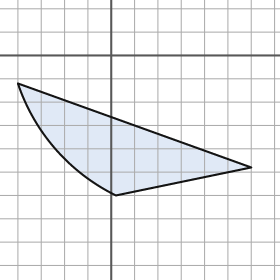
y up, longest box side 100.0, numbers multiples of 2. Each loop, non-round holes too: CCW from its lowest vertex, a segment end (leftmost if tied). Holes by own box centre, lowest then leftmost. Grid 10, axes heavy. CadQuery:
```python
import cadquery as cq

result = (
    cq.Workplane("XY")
    .moveTo(2.0, -60.0)
    .lineTo(60.0, -48.0)
    .lineTo(-40.0, -12.0)
    .threePointArc((-24.0, -40.0), (2.0, -60.0))
    .close()
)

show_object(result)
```